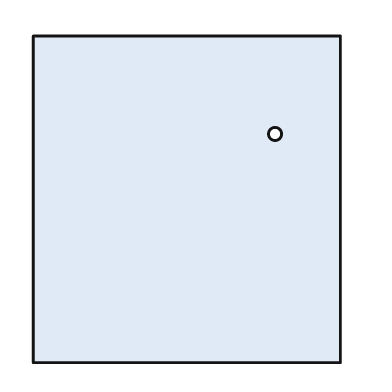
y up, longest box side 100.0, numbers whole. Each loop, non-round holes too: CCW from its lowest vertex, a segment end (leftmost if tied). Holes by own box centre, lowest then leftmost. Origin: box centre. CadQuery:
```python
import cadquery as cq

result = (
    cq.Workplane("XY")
    .moveTo(-47.0, -50.0)
    .lineTo(47.0, -50.0)
    .lineTo(47.0, 50.0)
    .lineTo(-47.0, 50.0)
    .close()
    .moveTo(27.0, 20.0)
    .circle(2.0)
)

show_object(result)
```